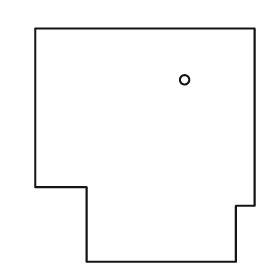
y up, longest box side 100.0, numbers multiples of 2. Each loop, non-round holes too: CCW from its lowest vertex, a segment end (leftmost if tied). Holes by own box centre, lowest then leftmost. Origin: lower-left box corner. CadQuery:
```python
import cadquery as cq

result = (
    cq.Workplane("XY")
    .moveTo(22.0, 0.0)
    .lineTo(86.0, 0.0)
    .lineTo(86.0, 24.0)
    .lineTo(94.0, 24.0)
    .lineTo(94.0, 100.0)
    .lineTo(0.0, 100.0)
    .lineTo(0.0, 32.0)
    .lineTo(22.0, 32.0)
    .close()
    .moveTo(64.0, 78.0)
    .circle(2.0)
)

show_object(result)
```